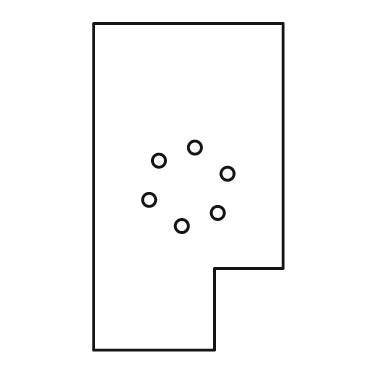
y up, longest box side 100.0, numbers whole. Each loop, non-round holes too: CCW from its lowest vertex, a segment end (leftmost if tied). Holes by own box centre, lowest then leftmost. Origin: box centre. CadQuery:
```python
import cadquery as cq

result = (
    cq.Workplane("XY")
    .moveTo(-29.0, -50.0)
    .lineTo(8.0, -50.0)
    .lineTo(8.0, -25.0)
    .lineTo(29.0, -25.0)
    .lineTo(29.0, 50.0)
    .lineTo(-29.0, 50.0)
    .close()
    .moveTo(-2.0, -12.0)
    .circle(2.0)
    .moveTo(9.0, -8.0)
    .circle(2.0)
    .moveTo(-12.0, -4.0)
    .circle(2.0)
    .moveTo(12.0, 4.0)
    .circle(2.0)
    .moveTo(-9.0, 8.0)
    .circle(2.0)
    .moveTo(2.0, 12.0)
    .circle(2.0)
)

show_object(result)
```